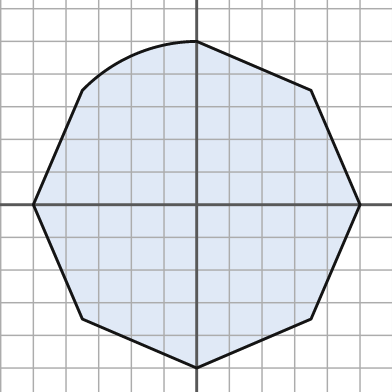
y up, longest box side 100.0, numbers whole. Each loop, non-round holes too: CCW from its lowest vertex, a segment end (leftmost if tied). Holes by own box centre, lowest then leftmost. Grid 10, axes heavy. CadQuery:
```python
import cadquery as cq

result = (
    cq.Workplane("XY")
    .moveTo(0.0, -50.0)
    .lineTo(35.0, -35.0)
    .lineTo(50.0, 0.0)
    .lineTo(35.0, 35.0)
    .lineTo(0.0, 50.0)
    .threePointArc((-19.0, 46.0), (-35.0, 35.0))
    .lineTo(-50.0, 0.0)
    .lineTo(-35.0, -35.0)
    .close()
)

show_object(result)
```